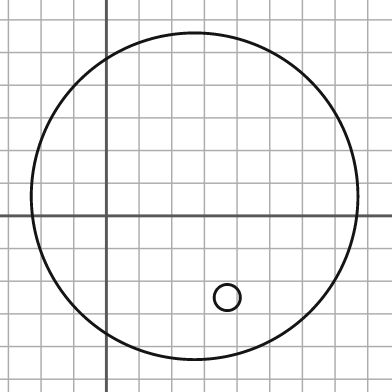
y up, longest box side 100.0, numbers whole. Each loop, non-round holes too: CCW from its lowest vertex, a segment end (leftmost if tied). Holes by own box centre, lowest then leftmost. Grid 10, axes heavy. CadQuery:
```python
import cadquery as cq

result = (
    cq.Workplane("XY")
    .moveTo(27.0, 6.0)
    .circle(50.0)
    .moveTo(37.0, -25.0)
    .circle(4.0)
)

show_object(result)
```